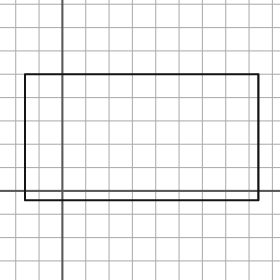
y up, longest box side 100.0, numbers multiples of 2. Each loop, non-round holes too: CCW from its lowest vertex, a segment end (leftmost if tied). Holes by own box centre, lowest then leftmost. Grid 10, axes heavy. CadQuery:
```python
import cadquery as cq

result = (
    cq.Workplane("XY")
    .moveTo(-16.0, -4.0)
    .lineTo(84.0, -4.0)
    .lineTo(84.0, 50.0)
    .lineTo(-16.0, 50.0)
    .close()
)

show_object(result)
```